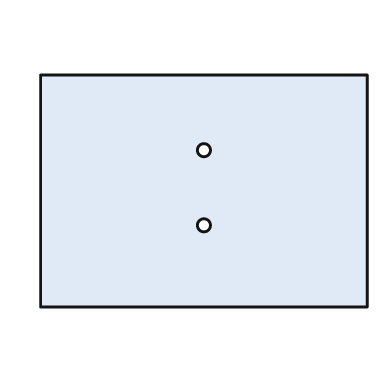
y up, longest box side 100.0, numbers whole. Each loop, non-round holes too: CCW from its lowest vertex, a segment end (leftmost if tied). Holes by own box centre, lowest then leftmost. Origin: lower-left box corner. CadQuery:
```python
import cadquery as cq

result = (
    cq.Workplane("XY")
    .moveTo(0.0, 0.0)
    .lineTo(100.0, 0.0)
    .lineTo(100.0, 71.0)
    .lineTo(0.0, 71.0)
    .close()
    .moveTo(50.0, 25.0)
    .circle(2.0)
    .moveTo(50.0, 48.0)
    .circle(2.0)
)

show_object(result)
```